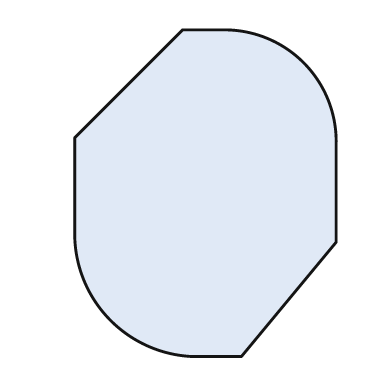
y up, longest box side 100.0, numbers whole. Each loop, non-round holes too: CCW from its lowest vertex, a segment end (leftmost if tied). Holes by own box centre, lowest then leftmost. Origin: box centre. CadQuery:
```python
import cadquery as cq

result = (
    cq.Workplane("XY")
    .moveTo(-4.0, -50.0)
    .lineTo(11.0, -50.0)
    .lineTo(40.0, -15.0)
    .lineTo(40.0, 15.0)
    .threePointArc((30.0, 40.0), (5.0, 50.0))
    .lineTo(-7.0, 50.0)
    .lineTo(-40.0, 17.0)
    .lineTo(-40.0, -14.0)
    .threePointArc((-29.0, -39.0), (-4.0, -50.0))
    .close()
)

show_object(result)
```